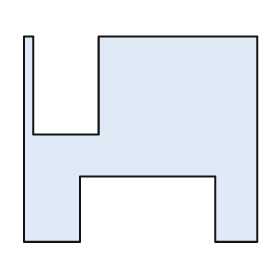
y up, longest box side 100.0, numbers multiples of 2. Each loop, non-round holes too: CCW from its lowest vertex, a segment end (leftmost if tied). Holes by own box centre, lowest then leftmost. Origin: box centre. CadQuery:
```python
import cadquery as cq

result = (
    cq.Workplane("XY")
    .moveTo(-50.0, -44.0)
    .lineTo(-26.0, -44.0)
    .lineTo(-26.0, -16.0)
    .lineTo(32.0, -16.0)
    .lineTo(32.0, -44.0)
    .lineTo(50.0, -44.0)
    .lineTo(50.0, 44.0)
    .lineTo(-18.0, 44.0)
    .lineTo(-18.0, 2.0)
    .lineTo(-46.0, 2.0)
    .lineTo(-46.0, 44.0)
    .lineTo(-50.0, 44.0)
    .close()
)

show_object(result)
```